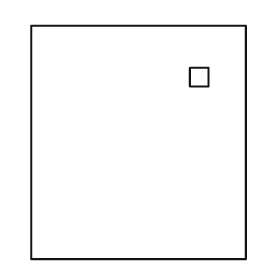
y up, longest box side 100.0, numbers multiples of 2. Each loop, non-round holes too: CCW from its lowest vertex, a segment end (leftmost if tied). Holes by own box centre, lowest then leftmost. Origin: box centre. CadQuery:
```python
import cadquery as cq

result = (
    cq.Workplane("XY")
    .moveTo(-46.0, -50.0)
    .lineTo(46.0, -50.0)
    .lineTo(46.0, 50.0)
    .lineTo(-46.0, 50.0)
    .close()
    .moveTo(22.0, 24.0)
    .lineTo(30.0, 24.0)
    .lineTo(30.0, 32.0)
    .lineTo(22.0, 32.0)
    .close()
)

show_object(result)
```